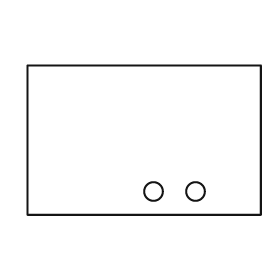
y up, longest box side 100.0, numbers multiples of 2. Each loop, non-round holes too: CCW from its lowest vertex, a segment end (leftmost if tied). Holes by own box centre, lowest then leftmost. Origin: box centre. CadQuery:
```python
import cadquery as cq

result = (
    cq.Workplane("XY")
    .moveTo(-50.0, -32.0)
    .lineTo(50.0, -32.0)
    .lineTo(50.0, 32.0)
    .lineTo(-50.0, 32.0)
    .close()
    .moveTo(4.0, -22.0)
    .circle(4.0)
    .moveTo(22.0, -22.0)
    .circle(4.0)
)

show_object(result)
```